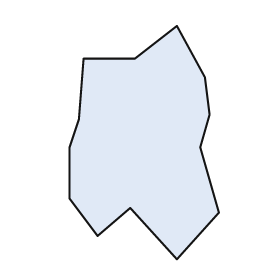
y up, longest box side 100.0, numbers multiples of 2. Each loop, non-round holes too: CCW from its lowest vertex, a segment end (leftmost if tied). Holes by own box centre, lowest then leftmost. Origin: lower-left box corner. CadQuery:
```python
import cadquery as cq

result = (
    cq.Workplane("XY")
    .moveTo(46.0, 0.0)
    .lineTo(64.0, 20.0)
    .lineTo(56.0, 48.0)
    .lineTo(60.0, 62.0)
    .lineTo(58.0, 78.0)
    .lineTo(46.0, 100.0)
    .lineTo(28.0, 86.0)
    .lineTo(6.0, 86.0)
    .lineTo(4.0, 60.0)
    .lineTo(0.0, 48.0)
    .lineTo(0.0, 26.0)
    .lineTo(12.0, 10.0)
    .lineTo(26.0, 22.0)
    .close()
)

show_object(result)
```